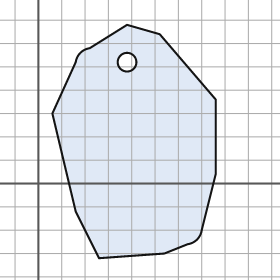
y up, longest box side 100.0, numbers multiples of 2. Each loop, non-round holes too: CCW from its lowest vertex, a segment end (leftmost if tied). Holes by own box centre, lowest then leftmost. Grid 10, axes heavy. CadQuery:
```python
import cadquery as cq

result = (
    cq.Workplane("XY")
    .moveTo(26.0, -32.0)
    .lineTo(54.0, -30.0)
    .lineTo(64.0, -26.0)
    .threePointArc((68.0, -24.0), (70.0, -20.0))
    .lineTo(76.0, 4.0)
    .lineTo(76.0, 36.0)
    .lineTo(52.0, 64.0)
    .lineTo(38.0, 68.0)
    .lineTo(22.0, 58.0)
    .threePointArc((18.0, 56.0), (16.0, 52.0))
    .lineTo(6.0, 30.0)
    .lineTo(16.0, -12.0)
    .close()
    .moveTo(38.0, 52.0)
    .circle(4.0)
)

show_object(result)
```